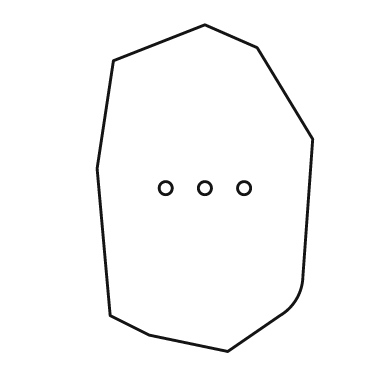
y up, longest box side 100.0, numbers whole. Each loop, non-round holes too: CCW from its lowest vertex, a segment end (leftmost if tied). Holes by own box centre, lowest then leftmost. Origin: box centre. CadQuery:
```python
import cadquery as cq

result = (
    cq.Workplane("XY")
    .moveTo(7.0, -50.0)
    .lineTo(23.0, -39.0)
    .threePointArc((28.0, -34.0), (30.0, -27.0))
    .lineTo(33.0, 15.0)
    .lineTo(16.0, 43.0)
    .lineTo(0.0, 50.0)
    .lineTo(-28.0, 39.0)
    .lineTo(-33.0, 6.0)
    .lineTo(-29.0, -39.0)
    .lineTo(-17.0, -45.0)
    .close()
    .moveTo(-12.0, 0.0)
    .circle(2.0)
    .moveTo(0.0, 0.0)
    .circle(2.0)
    .moveTo(12.0, 0.0)
    .circle(2.0)
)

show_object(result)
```